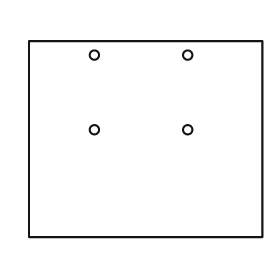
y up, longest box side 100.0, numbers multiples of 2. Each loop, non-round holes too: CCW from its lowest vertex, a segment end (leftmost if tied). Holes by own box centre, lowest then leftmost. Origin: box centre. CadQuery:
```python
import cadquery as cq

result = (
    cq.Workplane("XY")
    .moveTo(-50.0, -42.0)
    .lineTo(50.0, -42.0)
    .lineTo(50.0, 42.0)
    .lineTo(-50.0, 42.0)
    .close()
    .moveTo(-22.0, 4.0)
    .circle(2.0)
    .moveTo(18.0, 4.0)
    .circle(2.0)
    .moveTo(-22.0, 36.0)
    .circle(2.0)
    .moveTo(18.0, 36.0)
    .circle(2.0)
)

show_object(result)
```